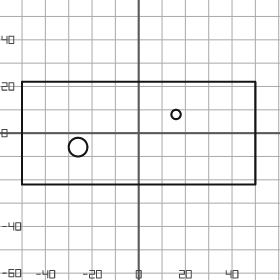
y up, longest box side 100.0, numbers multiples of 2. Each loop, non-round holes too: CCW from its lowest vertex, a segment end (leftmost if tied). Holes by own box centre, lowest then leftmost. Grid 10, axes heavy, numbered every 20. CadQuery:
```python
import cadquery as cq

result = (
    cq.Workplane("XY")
    .moveTo(-50.0, -22.0)
    .lineTo(50.0, -22.0)
    .lineTo(50.0, 22.0)
    .lineTo(-50.0, 22.0)
    .close()
    .moveTo(-26.0, -6.0)
    .circle(4.0)
    .moveTo(16.0, 8.0)
    .circle(2.0)
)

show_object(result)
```